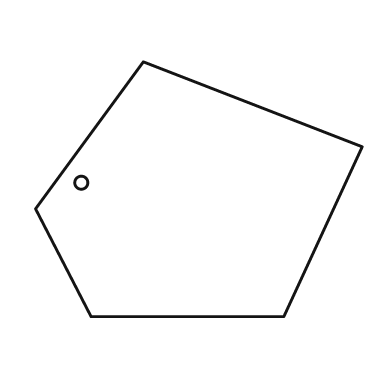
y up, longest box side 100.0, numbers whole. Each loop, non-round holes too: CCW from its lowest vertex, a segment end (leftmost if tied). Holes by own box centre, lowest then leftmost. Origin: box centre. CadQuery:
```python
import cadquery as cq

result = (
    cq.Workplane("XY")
    .moveTo(-33.0, -39.0)
    .lineTo(26.0, -39.0)
    .lineTo(50.0, 13.0)
    .lineTo(-17.0, 39.0)
    .lineTo(-50.0, -6.0)
    .close()
    .moveTo(-36.0, 2.0)
    .circle(2.0)
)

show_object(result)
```